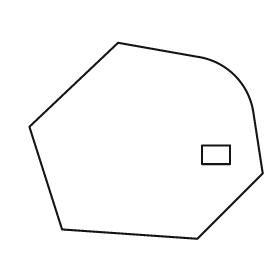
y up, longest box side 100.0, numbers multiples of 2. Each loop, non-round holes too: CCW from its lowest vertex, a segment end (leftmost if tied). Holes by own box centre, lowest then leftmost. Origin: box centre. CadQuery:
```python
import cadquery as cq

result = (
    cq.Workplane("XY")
    .moveTo(22.0, -42.0)
    .lineTo(50.0, -14.0)
    .lineTo(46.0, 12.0)
    .threePointArc((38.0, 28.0), (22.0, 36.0))
    .lineTo(-12.0, 42.0)
    .lineTo(-50.0, 6.0)
    .lineTo(-36.0, -38.0)
    .close()
    .moveTo(24.0, -10.0)
    .lineTo(36.0, -10.0)
    .lineTo(36.0, -2.0)
    .lineTo(24.0, -2.0)
    .close()
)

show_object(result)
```